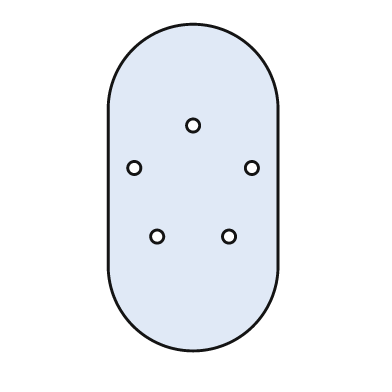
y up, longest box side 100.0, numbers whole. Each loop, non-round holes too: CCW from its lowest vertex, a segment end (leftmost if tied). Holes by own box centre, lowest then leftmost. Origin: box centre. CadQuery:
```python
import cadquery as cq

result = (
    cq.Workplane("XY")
    .moveTo(-26.0, -24.0)
    .threePointArc((0.0, -50.0), (26.0, -24.0))
    .lineTo(26.0, 24.0)
    .threePointArc((0.0, 50.0), (-26.0, 24.0))
    .close()
    .moveTo(-11.0, -15.0)
    .circle(2.0)
    .moveTo(11.0, -15.0)
    .circle(2.0)
    .moveTo(-18.0, 6.0)
    .circle(2.0)
    .moveTo(18.0, 6.0)
    .circle(2.0)
    .moveTo(0.0, 19.0)
    .circle(2.0)
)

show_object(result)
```